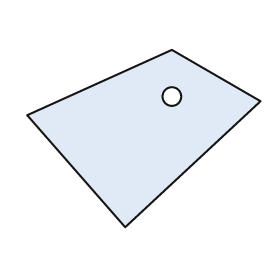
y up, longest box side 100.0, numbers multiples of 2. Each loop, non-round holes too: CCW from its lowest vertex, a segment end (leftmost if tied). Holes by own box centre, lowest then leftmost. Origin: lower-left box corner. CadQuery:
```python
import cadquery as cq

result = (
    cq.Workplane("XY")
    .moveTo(42.0, 0.0)
    .lineTo(100.0, 54.0)
    .lineTo(62.0, 76.0)
    .lineTo(0.0, 48.0)
    .close()
    .moveTo(62.0, 56.0)
    .circle(4.0)
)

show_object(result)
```